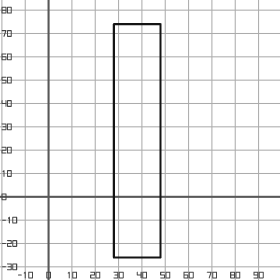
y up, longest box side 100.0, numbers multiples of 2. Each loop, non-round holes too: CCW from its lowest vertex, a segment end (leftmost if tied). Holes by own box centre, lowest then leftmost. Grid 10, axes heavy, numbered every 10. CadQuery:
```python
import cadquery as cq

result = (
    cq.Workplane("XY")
    .moveTo(28.0, -26.0)
    .lineTo(48.0, -26.0)
    .lineTo(48.0, 74.0)
    .lineTo(28.0, 74.0)
    .close()
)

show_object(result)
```